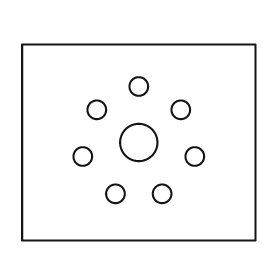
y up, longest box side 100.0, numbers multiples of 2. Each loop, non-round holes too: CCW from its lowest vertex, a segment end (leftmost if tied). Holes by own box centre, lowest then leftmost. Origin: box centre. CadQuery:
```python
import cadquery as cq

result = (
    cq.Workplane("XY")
    .moveTo(-50.0, -42.0)
    .lineTo(50.0, -42.0)
    .lineTo(50.0, 42.0)
    .lineTo(-50.0, 42.0)
    .close()
    .moveTo(-10.0, -22.0)
    .circle(4.0)
    .moveTo(10.0, -22.0)
    .circle(4.0)
    .moveTo(-24.0, -6.0)
    .circle(4.0)
    .moveTo(24.0, -6.0)
    .circle(4.0)
    .moveTo(0.0, 0.0)
    .circle(8.0)
    .moveTo(-18.0, 14.0)
    .circle(4.0)
    .moveTo(18.0, 14.0)
    .circle(4.0)
    .moveTo(0.0, 24.0)
    .circle(4.0)
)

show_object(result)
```